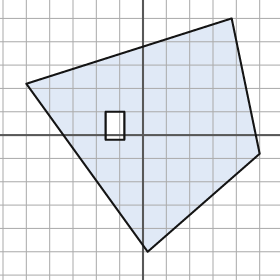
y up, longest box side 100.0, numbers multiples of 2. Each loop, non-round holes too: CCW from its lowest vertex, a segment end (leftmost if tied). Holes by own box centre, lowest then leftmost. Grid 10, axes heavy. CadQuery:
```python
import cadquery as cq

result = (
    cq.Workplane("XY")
    .moveTo(2.0, -50.0)
    .lineTo(50.0, -8.0)
    .lineTo(38.0, 50.0)
    .lineTo(-50.0, 22.0)
    .close()
    .moveTo(-16.0, -2.0)
    .lineTo(-8.0, -2.0)
    .lineTo(-8.0, 10.0)
    .lineTo(-16.0, 10.0)
    .close()
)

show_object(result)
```